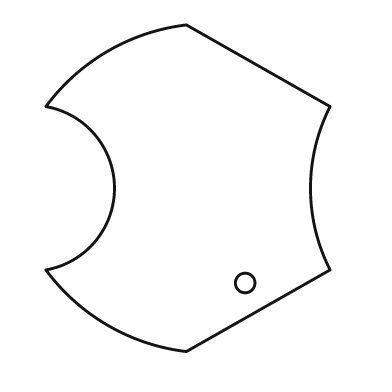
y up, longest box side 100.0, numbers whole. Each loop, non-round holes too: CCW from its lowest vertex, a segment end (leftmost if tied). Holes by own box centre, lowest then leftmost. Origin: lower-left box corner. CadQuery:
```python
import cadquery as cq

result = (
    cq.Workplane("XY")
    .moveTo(43.0, 0.0)
    .lineTo(87.0, 25.0)
    .threePointArc((81.0, 50.0), (87.0, 75.0))
    .lineTo(43.0, 100.0)
    .threePointArc((19.0, 92.0), (0.0, 75.0))
    .threePointArc((21.0, 50.0), (0.0, 25.0))
    .threePointArc((19.0, 8.0), (43.0, 0.0))
    .close()
    .moveTo(61.0, 21.0)
    .circle(3.0)
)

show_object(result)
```